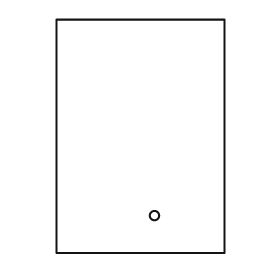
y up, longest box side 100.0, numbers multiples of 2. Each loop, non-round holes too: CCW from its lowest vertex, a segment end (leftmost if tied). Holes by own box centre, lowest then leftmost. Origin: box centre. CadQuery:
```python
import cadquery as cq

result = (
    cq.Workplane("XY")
    .moveTo(-36.0, -50.0)
    .lineTo(36.0, -50.0)
    .lineTo(36.0, 50.0)
    .lineTo(-36.0, 50.0)
    .close()
    .moveTo(6.0, -34.0)
    .circle(2.0)
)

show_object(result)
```